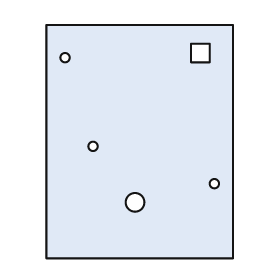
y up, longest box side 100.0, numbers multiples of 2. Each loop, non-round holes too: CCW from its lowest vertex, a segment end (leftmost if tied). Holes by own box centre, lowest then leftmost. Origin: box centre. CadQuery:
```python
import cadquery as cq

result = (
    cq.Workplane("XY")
    .moveTo(-40.0, -50.0)
    .lineTo(40.0, -50.0)
    .lineTo(40.0, 50.0)
    .lineTo(-40.0, 50.0)
    .close()
    .moveTo(-2.0, -26.0)
    .circle(4.0)
    .moveTo(32.0, -18.0)
    .circle(2.0)
    .moveTo(-20.0, -2.0)
    .circle(2.0)
    .moveTo(-32.0, 36.0)
    .circle(2.0)
    .moveTo(22.0, 34.0)
    .lineTo(30.0, 34.0)
    .lineTo(30.0, 42.0)
    .lineTo(22.0, 42.0)
    .close()
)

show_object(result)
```